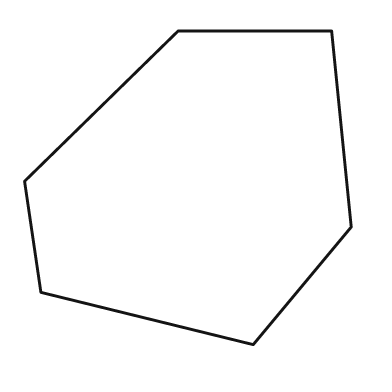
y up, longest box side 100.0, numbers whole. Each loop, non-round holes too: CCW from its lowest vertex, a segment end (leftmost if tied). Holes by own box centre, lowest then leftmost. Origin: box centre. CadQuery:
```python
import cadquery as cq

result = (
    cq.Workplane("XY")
    .moveTo(20.0, -48.0)
    .lineTo(50.0, -12.0)
    .lineTo(44.0, 48.0)
    .lineTo(-3.0, 48.0)
    .lineTo(-50.0, 2.0)
    .lineTo(-45.0, -32.0)
    .close()
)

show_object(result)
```